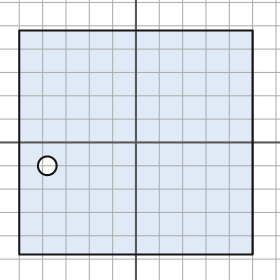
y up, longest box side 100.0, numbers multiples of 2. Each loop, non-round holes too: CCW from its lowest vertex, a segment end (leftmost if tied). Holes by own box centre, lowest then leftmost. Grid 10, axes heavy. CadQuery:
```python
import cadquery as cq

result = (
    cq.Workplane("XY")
    .moveTo(-50.0, -48.0)
    .lineTo(50.0, -48.0)
    .lineTo(50.0, 48.0)
    .lineTo(-50.0, 48.0)
    .close()
    .moveTo(-38.0, -10.0)
    .circle(4.0)
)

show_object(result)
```